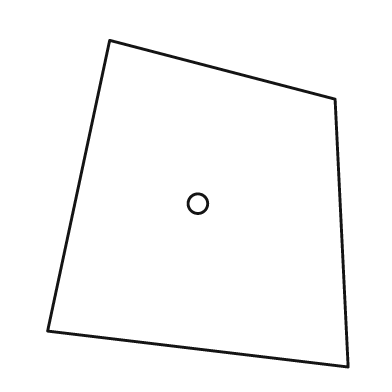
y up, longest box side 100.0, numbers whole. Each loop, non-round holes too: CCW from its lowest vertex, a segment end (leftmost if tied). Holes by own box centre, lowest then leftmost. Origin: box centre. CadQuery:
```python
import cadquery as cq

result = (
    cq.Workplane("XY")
    .moveTo(46.0, -50.0)
    .lineTo(42.0, 32.0)
    .lineTo(-27.0, 50.0)
    .lineTo(-46.0, -39.0)
    .close()
    .moveTo(0.0, 0.0)
    .circle(3.0)
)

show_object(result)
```